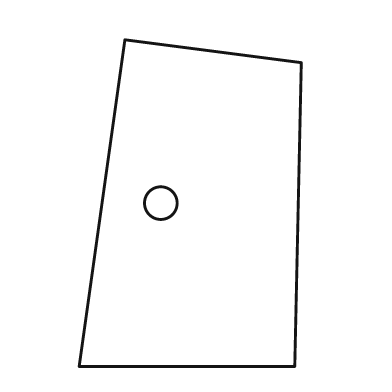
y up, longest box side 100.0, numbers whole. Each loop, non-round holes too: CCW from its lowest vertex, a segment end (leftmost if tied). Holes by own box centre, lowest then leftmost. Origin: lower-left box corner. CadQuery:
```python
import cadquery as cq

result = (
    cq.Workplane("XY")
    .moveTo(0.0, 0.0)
    .lineTo(66.0, 0.0)
    .lineTo(68.0, 93.0)
    .lineTo(14.0, 100.0)
    .close()
    .moveTo(25.0, 50.0)
    .circle(5.0)
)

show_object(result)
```